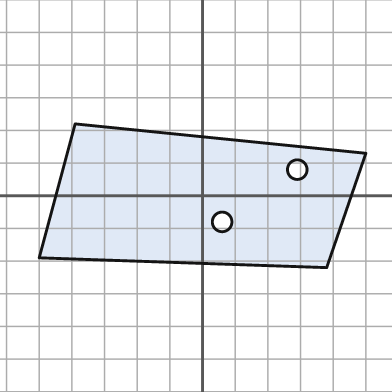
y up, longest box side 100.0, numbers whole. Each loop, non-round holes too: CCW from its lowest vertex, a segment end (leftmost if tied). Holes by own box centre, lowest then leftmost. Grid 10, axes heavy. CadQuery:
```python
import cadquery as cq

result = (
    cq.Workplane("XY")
    .moveTo(38.0, -22.0)
    .lineTo(50.0, 13.0)
    .lineTo(-39.0, 22.0)
    .lineTo(-50.0, -19.0)
    .close()
    .moveTo(6.0, -8.0)
    .circle(3.0)
    .moveTo(29.0, 8.0)
    .circle(3.0)
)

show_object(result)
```